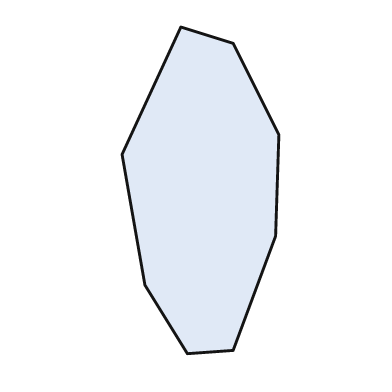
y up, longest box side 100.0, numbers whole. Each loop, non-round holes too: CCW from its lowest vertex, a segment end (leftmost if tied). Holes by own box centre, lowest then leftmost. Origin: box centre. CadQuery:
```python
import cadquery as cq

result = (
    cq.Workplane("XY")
    .moveTo(-4.0, -50.0)
    .lineTo(10.0, -49.0)
    .lineTo(23.0, -14.0)
    .lineTo(24.0, 17.0)
    .lineTo(10.0, 45.0)
    .lineTo(-6.0, 50.0)
    .lineTo(-24.0, 11.0)
    .lineTo(-17.0, -29.0)
    .close()
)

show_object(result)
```